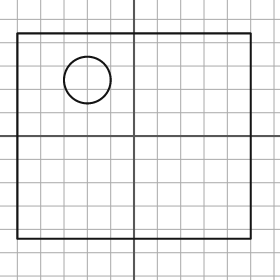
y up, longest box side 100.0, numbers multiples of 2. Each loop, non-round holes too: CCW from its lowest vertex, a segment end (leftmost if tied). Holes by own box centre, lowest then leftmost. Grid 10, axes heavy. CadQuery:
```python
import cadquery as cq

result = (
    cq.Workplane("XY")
    .moveTo(-50.0, -44.0)
    .lineTo(50.0, -44.0)
    .lineTo(50.0, 44.0)
    .lineTo(-50.0, 44.0)
    .close()
    .moveTo(-20.0, 24.0)
    .circle(10.0)
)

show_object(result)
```